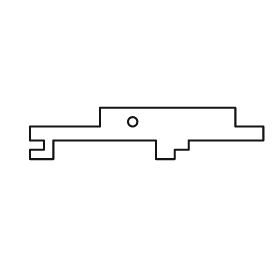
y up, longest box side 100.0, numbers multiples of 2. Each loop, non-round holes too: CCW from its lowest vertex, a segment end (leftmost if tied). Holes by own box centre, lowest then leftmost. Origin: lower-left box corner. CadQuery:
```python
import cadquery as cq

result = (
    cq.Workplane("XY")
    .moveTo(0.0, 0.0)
    .lineTo(10.0, 0.0)
    .lineTo(10.0, 8.0)
    .lineTo(54.0, 8.0)
    .lineTo(54.0, 0.0)
    .lineTo(62.0, 0.0)
    .lineTo(62.0, 4.0)
    .lineTo(68.0, 4.0)
    .lineTo(68.0, 8.0)
    .lineTo(100.0, 8.0)
    .lineTo(100.0, 14.0)
    .lineTo(88.0, 14.0)
    .lineTo(88.0, 22.0)
    .lineTo(30.0, 22.0)
    .lineTo(30.0, 14.0)
    .lineTo(0.0, 14.0)
    .lineTo(0.0, 8.0)
    .lineTo(6.0, 8.0)
    .lineTo(6.0, 4.0)
    .lineTo(0.0, 4.0)
    .close()
    .moveTo(44.0, 16.0)
    .circle(2.0)
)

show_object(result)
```